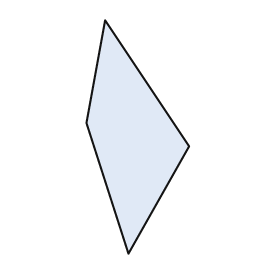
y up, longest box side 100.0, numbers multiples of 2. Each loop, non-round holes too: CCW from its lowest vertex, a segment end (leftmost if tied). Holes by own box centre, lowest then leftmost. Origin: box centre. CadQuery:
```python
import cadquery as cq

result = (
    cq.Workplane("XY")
    .moveTo(-4.0, -50.0)
    .lineTo(22.0, -4.0)
    .lineTo(-14.0, 50.0)
    .lineTo(-22.0, 6.0)
    .close()
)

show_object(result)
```